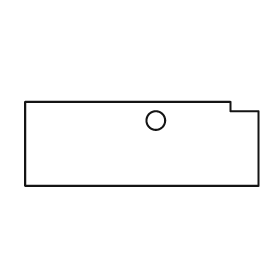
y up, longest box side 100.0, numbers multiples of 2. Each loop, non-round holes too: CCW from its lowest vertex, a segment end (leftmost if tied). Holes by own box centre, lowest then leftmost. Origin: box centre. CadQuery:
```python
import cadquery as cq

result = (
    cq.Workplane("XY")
    .moveTo(-50.0, -18.0)
    .lineTo(50.0, -18.0)
    .lineTo(50.0, 14.0)
    .lineTo(38.0, 14.0)
    .lineTo(38.0, 18.0)
    .lineTo(-50.0, 18.0)
    .close()
    .moveTo(6.0, 10.0)
    .circle(4.0)
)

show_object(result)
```